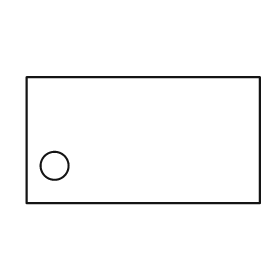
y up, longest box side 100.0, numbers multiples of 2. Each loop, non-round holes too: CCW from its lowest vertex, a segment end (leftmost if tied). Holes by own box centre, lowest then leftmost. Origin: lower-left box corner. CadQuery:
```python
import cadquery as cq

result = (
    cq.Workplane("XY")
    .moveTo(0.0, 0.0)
    .lineTo(100.0, 0.0)
    .lineTo(100.0, 54.0)
    .lineTo(0.0, 54.0)
    .close()
    .moveTo(12.0, 16.0)
    .circle(6.0)
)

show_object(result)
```